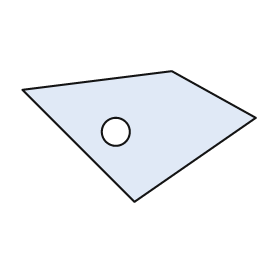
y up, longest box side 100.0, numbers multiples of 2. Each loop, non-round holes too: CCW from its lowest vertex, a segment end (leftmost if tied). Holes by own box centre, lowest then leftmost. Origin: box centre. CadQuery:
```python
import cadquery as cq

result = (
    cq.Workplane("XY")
    .moveTo(-2.0, -28.0)
    .lineTo(50.0, 8.0)
    .lineTo(14.0, 28.0)
    .lineTo(-50.0, 20.0)
    .close()
    .moveTo(-10.0, 2.0)
    .circle(6.0)
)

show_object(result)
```